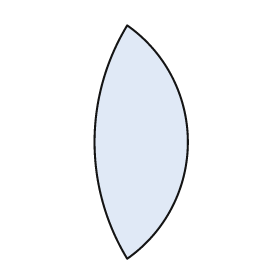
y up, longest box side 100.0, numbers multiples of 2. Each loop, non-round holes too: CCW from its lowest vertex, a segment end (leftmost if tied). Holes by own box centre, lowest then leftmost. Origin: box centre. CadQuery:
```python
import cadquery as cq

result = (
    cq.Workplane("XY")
    .moveTo(-6.0, -50.0)
    .threePointArc((20.0, 0.0), (-6.0, 50.0))
    .threePointArc((-20.0, 0.0), (-6.0, -50.0))
    .close()
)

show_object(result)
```